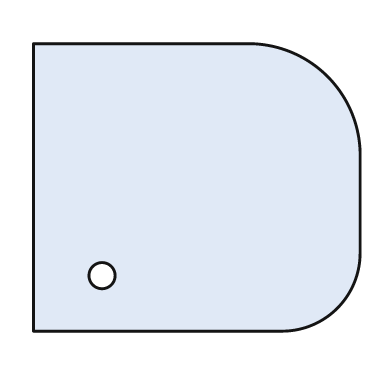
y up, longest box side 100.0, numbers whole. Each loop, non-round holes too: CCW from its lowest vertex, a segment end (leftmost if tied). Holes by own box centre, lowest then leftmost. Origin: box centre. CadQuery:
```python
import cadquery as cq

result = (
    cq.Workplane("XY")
    .moveTo(-50.0, -44.0)
    .lineTo(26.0, -44.0)
    .threePointArc((43.0, -37.0), (50.0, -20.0))
    .lineTo(50.0, 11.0)
    .threePointArc((40.0, 34.0), (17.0, 44.0))
    .lineTo(-50.0, 44.0)
    .close()
    .moveTo(-29.0, -27.0)
    .circle(4.0)
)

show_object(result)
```